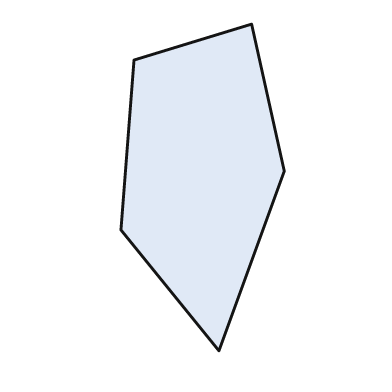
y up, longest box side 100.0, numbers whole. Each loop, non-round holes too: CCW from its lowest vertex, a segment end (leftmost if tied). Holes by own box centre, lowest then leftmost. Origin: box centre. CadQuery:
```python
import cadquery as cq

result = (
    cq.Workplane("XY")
    .moveTo(5.0, -50.0)
    .lineTo(25.0, 5.0)
    .lineTo(15.0, 50.0)
    .lineTo(-21.0, 39.0)
    .lineTo(-25.0, -13.0)
    .close()
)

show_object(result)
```